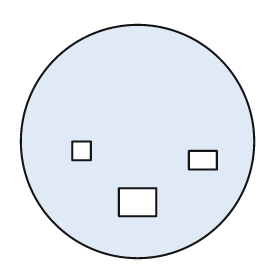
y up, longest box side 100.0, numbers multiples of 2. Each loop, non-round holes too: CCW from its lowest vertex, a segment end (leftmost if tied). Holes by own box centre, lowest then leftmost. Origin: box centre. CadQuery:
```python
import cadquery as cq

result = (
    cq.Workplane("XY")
    .moveTo(0.0, 0.0)
    .circle(50.0)
    .moveTo(-8.0, -32.0)
    .lineTo(8.0, -32.0)
    .lineTo(8.0, -20.0)
    .lineTo(-8.0, -20.0)
    .close()
    .moveTo(22.0, -12.0)
    .lineTo(34.0, -12.0)
    .lineTo(34.0, -4.0)
    .lineTo(22.0, -4.0)
    .close()
    .moveTo(-28.0, -8.0)
    .lineTo(-20.0, -8.0)
    .lineTo(-20.0, 0.0)
    .lineTo(-28.0, 0.0)
    .close()
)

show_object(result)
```